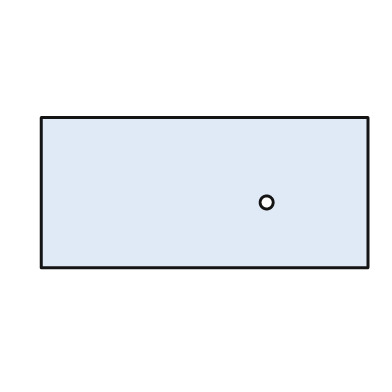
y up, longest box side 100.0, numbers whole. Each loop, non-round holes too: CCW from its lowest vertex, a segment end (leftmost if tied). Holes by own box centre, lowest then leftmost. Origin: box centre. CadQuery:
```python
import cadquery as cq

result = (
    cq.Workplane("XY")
    .moveTo(-50.0, -23.0)
    .lineTo(50.0, -23.0)
    .lineTo(50.0, 23.0)
    .lineTo(-50.0, 23.0)
    .close()
    .moveTo(19.0, -3.0)
    .circle(2.0)
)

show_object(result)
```